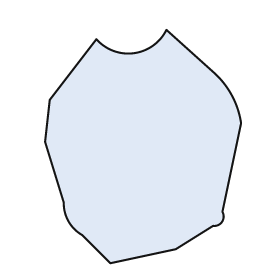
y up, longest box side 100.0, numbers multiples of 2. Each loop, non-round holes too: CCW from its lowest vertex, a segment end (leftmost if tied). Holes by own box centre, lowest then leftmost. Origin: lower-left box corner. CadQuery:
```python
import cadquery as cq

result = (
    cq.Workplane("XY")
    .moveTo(28.0, 0.0)
    .lineTo(56.0, 6.0)
    .lineTo(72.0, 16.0)
    .threePointArc((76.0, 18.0), (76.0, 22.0))
    .lineTo(84.0, 60.0)
    .threePointArc((80.0, 72.0), (72.0, 82.0))
    .lineTo(52.0, 100.0)
    .threePointArc((38.0, 90.0), (22.0, 96.0))
    .lineTo(2.0, 70.0)
    .lineTo(0.0, 52.0)
    .lineTo(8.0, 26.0)
    .threePointArc((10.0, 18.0), (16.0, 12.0))
    .close()
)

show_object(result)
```